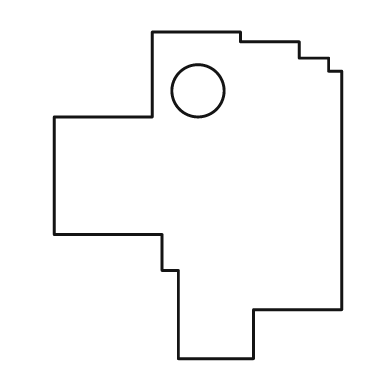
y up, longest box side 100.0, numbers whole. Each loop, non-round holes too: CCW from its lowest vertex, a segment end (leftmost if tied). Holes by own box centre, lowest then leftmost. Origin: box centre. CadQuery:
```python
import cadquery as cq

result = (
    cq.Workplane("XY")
    .moveTo(-6.0, -50.0)
    .lineTo(17.0, -50.0)
    .lineTo(17.0, -35.0)
    .lineTo(44.0, -35.0)
    .lineTo(44.0, 38.0)
    .lineTo(40.0, 38.0)
    .lineTo(40.0, 42.0)
    .lineTo(31.0, 42.0)
    .lineTo(31.0, 47.0)
    .lineTo(13.0, 47.0)
    .lineTo(13.0, 50.0)
    .lineTo(-14.0, 50.0)
    .lineTo(-14.0, 24.0)
    .lineTo(-44.0, 24.0)
    .lineTo(-44.0, -12.0)
    .lineTo(-11.0, -12.0)
    .lineTo(-11.0, -23.0)
    .lineTo(-6.0, -23.0)
    .close()
    .moveTo(0.0, 32.0)
    .circle(8.0)
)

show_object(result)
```